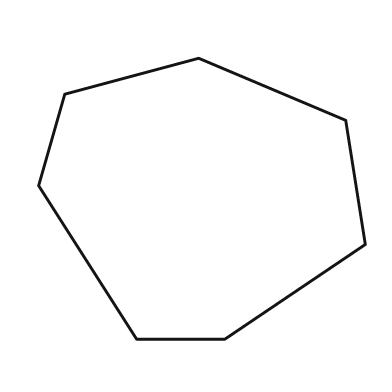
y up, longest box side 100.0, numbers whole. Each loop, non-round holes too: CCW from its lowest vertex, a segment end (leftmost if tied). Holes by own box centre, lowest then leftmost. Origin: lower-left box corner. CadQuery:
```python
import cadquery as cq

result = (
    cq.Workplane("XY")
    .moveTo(30.0, 0.0)
    .lineTo(57.0, 0.0)
    .lineTo(100.0, 29.0)
    .lineTo(94.0, 67.0)
    .lineTo(49.0, 86.0)
    .lineTo(8.0, 75.0)
    .lineTo(0.0, 47.0)
    .close()
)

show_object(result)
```